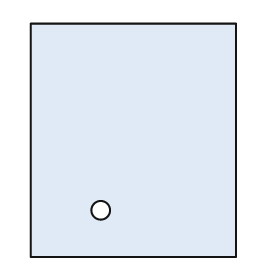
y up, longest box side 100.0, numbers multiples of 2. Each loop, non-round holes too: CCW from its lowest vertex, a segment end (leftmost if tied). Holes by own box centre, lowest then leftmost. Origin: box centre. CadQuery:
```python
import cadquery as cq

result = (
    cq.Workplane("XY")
    .moveTo(-44.0, -50.0)
    .lineTo(44.0, -50.0)
    .lineTo(44.0, 50.0)
    .lineTo(-44.0, 50.0)
    .close()
    .moveTo(-14.0, -30.0)
    .circle(4.0)
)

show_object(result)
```